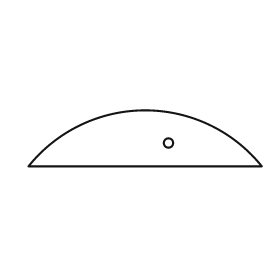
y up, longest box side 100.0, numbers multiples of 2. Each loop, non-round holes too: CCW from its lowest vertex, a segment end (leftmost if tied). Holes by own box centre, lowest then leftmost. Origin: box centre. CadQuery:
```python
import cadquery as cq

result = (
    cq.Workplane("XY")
    .moveTo(-50.0, -12.0)
    .lineTo(50.0, -12.0)
    .threePointArc((0.0, 12.0), (-50.0, -12.0))
    .close()
    .moveTo(10.0, -2.0)
    .circle(2.0)
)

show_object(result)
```